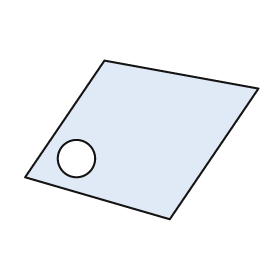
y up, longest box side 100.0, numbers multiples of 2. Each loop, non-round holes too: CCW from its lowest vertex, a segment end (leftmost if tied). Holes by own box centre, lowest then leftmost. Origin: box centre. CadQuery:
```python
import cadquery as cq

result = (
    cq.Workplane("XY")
    .moveTo(12.0, -34.0)
    .lineTo(50.0, 22.0)
    .lineTo(-16.0, 34.0)
    .lineTo(-50.0, -16.0)
    .close()
    .moveTo(-28.0, -8.0)
    .circle(8.0)
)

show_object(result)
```